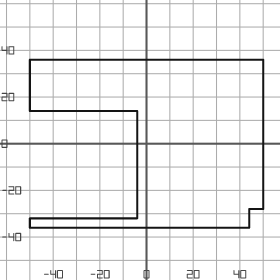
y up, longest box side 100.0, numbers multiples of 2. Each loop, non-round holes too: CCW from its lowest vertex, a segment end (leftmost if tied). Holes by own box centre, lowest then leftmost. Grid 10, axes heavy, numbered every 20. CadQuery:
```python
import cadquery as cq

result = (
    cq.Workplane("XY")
    .moveTo(-50.0, -36.0)
    .lineTo(44.0, -36.0)
    .lineTo(44.0, -28.0)
    .lineTo(50.0, -28.0)
    .lineTo(50.0, 36.0)
    .lineTo(-50.0, 36.0)
    .lineTo(-50.0, 14.0)
    .lineTo(-4.0, 14.0)
    .lineTo(-4.0, -32.0)
    .lineTo(-50.0, -32.0)
    .close()
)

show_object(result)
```